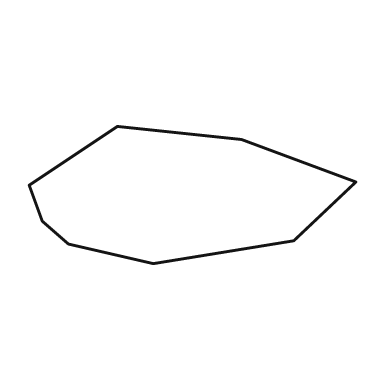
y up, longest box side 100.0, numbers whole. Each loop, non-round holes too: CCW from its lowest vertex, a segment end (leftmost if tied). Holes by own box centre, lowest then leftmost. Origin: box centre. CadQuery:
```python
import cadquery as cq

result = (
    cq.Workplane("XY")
    .moveTo(-12.0, -21.0)
    .lineTo(31.0, -14.0)
    .lineTo(50.0, 4.0)
    .lineTo(15.0, 17.0)
    .lineTo(-23.0, 21.0)
    .lineTo(-50.0, 3.0)
    .lineTo(-46.0, -8.0)
    .lineTo(-38.0, -15.0)
    .close()
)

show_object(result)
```